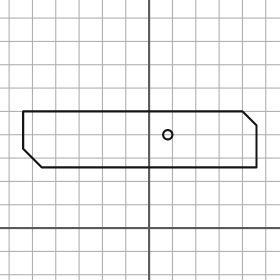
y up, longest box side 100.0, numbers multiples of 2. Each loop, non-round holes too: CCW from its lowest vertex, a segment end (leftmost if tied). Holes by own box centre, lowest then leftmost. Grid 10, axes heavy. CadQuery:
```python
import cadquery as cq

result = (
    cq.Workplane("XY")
    .moveTo(-46.0, 26.0)
    .lineTo(46.0, 26.0)
    .lineTo(46.0, 44.0)
    .lineTo(40.0, 50.0)
    .lineTo(-54.0, 50.0)
    .lineTo(-54.0, 34.0)
    .close()
    .moveTo(8.0, 40.0)
    .circle(2.0)
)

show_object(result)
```